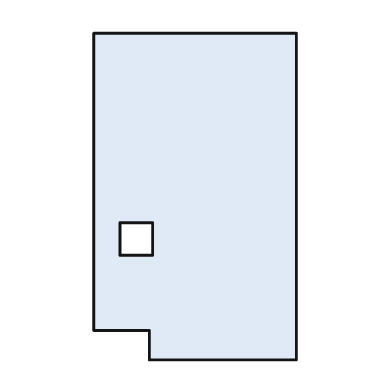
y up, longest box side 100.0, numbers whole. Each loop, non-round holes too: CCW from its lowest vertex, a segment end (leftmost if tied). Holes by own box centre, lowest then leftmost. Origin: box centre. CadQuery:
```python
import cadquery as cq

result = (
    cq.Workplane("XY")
    .moveTo(-14.0, -50.0)
    .lineTo(31.0, -50.0)
    .lineTo(31.0, 50.0)
    .lineTo(-31.0, 50.0)
    .lineTo(-31.0, -41.0)
    .lineTo(-14.0, -41.0)
    .close()
    .moveTo(-23.0, -18.0)
    .lineTo(-13.0, -18.0)
    .lineTo(-13.0, -8.0)
    .lineTo(-23.0, -8.0)
    .close()
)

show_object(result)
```